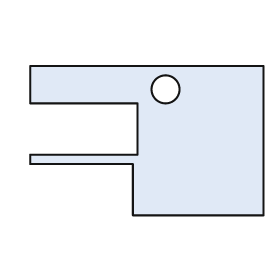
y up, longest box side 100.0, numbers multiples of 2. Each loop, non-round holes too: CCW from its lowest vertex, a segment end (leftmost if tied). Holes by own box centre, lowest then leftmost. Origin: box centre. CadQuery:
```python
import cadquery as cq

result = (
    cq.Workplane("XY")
    .moveTo(-6.0, -32.0)
    .lineTo(50.0, -32.0)
    .lineTo(50.0, 32.0)
    .lineTo(-50.0, 32.0)
    .lineTo(-50.0, 16.0)
    .lineTo(-4.0, 16.0)
    .lineTo(-4.0, -6.0)
    .lineTo(-50.0, -6.0)
    .lineTo(-50.0, -10.0)
    .lineTo(-6.0, -10.0)
    .close()
    .moveTo(8.0, 22.0)
    .circle(6.0)
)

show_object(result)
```